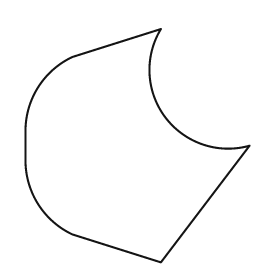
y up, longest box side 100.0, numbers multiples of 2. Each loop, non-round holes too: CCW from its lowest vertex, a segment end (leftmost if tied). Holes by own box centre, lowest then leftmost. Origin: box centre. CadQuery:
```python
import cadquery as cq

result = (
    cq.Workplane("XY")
    .moveTo(10.0, -50.0)
    .lineTo(48.0, 0.0)
    .threePointArc((12.0, 12.0), (10.0, 50.0))
    .lineTo(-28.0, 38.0)
    .threePointArc((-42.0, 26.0), (-48.0, 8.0))
    .lineTo(-48.0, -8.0)
    .threePointArc((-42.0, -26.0), (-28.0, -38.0))
    .close()
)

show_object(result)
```